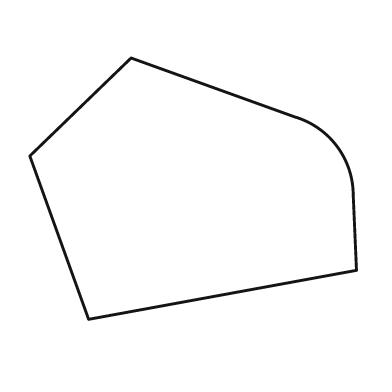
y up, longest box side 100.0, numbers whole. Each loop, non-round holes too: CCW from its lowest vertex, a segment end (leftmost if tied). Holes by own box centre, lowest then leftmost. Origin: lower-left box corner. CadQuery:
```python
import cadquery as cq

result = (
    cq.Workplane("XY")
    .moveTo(18.0, 0.0)
    .lineTo(100.0, 15.0)
    .lineTo(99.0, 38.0)
    .threePointArc((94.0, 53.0), (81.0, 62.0))
    .lineTo(31.0, 80.0)
    .lineTo(0.0, 50.0)
    .close()
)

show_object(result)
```